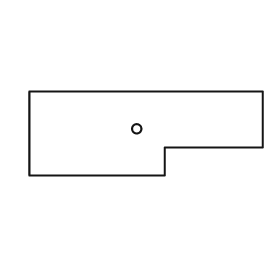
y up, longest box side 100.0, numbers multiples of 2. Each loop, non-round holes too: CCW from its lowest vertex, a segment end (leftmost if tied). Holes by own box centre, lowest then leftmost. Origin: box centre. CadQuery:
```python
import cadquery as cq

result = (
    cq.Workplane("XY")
    .moveTo(-50.0, -18.0)
    .lineTo(8.0, -18.0)
    .lineTo(8.0, -6.0)
    .lineTo(50.0, -6.0)
    .lineTo(50.0, 18.0)
    .lineTo(-50.0, 18.0)
    .close()
    .moveTo(-4.0, 2.0)
    .circle(2.0)
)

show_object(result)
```